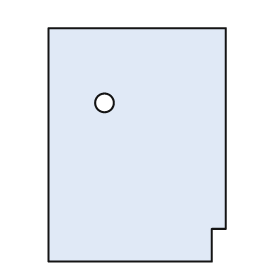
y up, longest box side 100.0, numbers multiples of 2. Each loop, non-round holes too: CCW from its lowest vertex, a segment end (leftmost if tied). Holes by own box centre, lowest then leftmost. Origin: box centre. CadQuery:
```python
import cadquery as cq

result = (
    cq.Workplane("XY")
    .moveTo(-38.0, -50.0)
    .lineTo(32.0, -50.0)
    .lineTo(32.0, -36.0)
    .lineTo(38.0, -36.0)
    .lineTo(38.0, 50.0)
    .lineTo(-38.0, 50.0)
    .close()
    .moveTo(-14.0, 18.0)
    .circle(4.0)
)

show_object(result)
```